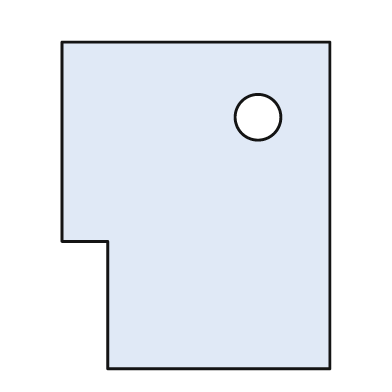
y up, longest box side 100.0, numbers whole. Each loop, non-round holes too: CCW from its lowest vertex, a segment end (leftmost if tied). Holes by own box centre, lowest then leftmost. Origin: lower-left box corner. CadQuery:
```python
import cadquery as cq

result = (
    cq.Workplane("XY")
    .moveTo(14.0, 0.0)
    .lineTo(82.0, 0.0)
    .lineTo(82.0, 100.0)
    .lineTo(0.0, 100.0)
    .lineTo(0.0, 39.0)
    .lineTo(14.0, 39.0)
    .close()
    .moveTo(60.0, 77.0)
    .circle(7.0)
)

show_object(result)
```